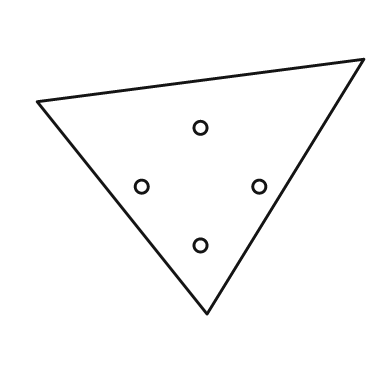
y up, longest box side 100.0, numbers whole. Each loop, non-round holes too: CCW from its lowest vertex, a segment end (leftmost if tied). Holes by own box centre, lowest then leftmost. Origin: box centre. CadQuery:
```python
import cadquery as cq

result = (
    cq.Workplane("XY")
    .moveTo(2.0, -39.0)
    .lineTo(50.0, 39.0)
    .lineTo(-50.0, 26.0)
    .close()
    .moveTo(0.0, -18.0)
    .circle(2.0)
    .moveTo(-18.0, 0.0)
    .circle(2.0)
    .moveTo(18.0, 0.0)
    .circle(2.0)
    .moveTo(0.0, 18.0)
    .circle(2.0)
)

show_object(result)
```